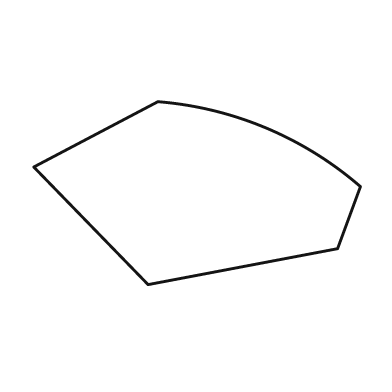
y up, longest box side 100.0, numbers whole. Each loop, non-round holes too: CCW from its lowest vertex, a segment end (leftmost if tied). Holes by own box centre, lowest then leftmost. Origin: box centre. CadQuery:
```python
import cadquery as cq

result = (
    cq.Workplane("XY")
    .moveTo(-15.0, -28.0)
    .lineTo(43.0, -17.0)
    .lineTo(50.0, 2.0)
    .threePointArc((21.0, 20.0), (-12.0, 28.0))
    .lineTo(-50.0, 8.0)
    .close()
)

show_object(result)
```